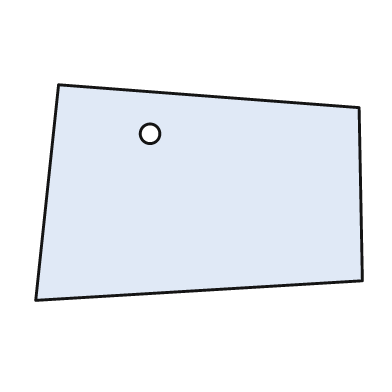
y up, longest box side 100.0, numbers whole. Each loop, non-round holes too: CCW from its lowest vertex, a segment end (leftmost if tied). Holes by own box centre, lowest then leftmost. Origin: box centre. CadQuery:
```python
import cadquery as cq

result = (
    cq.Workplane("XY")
    .moveTo(-50.0, -33.0)
    .lineTo(50.0, -27.0)
    .lineTo(49.0, 26.0)
    .lineTo(-43.0, 33.0)
    .close()
    .moveTo(-15.0, 18.0)
    .circle(3.0)
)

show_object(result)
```